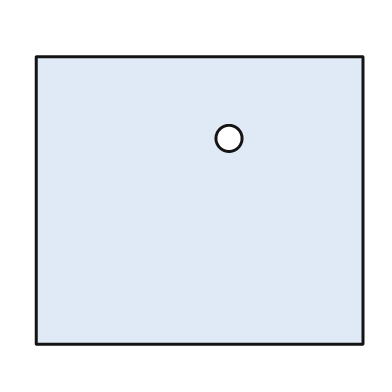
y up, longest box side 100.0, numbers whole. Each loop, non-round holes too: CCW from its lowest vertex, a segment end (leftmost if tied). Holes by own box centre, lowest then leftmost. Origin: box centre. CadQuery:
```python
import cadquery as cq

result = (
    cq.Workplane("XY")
    .moveTo(-50.0, -44.0)
    .lineTo(50.0, -44.0)
    .lineTo(50.0, 44.0)
    .lineTo(-50.0, 44.0)
    .close()
    .moveTo(9.0, 19.0)
    .circle(4.0)
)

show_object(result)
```